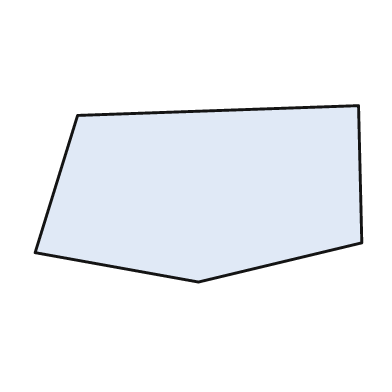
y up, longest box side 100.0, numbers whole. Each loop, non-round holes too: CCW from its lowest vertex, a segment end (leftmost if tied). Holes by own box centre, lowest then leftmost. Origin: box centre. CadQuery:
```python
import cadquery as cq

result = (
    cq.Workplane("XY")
    .moveTo(0.0, -27.0)
    .lineTo(50.0, -15.0)
    .lineTo(49.0, 27.0)
    .lineTo(-37.0, 24.0)
    .lineTo(-50.0, -18.0)
    .close()
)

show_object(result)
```